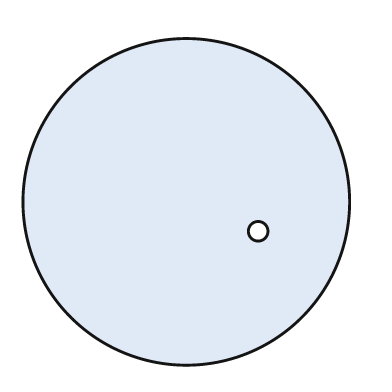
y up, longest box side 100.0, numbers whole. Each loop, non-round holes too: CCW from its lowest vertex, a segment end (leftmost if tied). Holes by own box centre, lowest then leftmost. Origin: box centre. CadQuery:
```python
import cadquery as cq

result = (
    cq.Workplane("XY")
    .moveTo(0.0, 0.0)
    .circle(50.0)
    .moveTo(22.0, -9.0)
    .circle(3.0)
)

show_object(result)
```